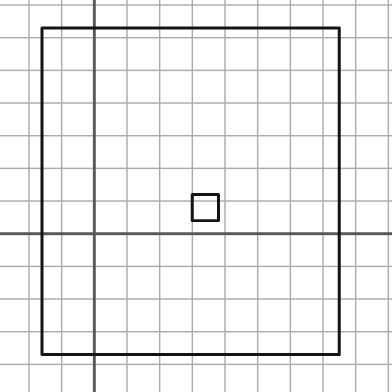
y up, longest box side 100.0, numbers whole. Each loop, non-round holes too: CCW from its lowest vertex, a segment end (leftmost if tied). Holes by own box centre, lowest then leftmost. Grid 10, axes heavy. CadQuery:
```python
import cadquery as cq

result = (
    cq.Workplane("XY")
    .moveTo(-16.0, -37.0)
    .lineTo(75.0, -37.0)
    .lineTo(75.0, 63.0)
    .lineTo(-16.0, 63.0)
    .close()
    .moveTo(30.0, 4.0)
    .lineTo(38.0, 4.0)
    .lineTo(38.0, 12.0)
    .lineTo(30.0, 12.0)
    .close()
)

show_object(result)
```